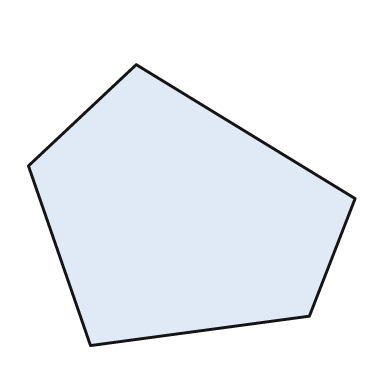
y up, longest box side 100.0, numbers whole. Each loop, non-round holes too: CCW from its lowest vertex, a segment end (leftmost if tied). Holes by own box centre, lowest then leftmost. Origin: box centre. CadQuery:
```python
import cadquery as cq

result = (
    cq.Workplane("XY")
    .moveTo(-31.0, -43.0)
    .lineTo(36.0, -34.0)
    .lineTo(50.0, 2.0)
    .lineTo(-17.0, 43.0)
    .lineTo(-50.0, 12.0)
    .close()
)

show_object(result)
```